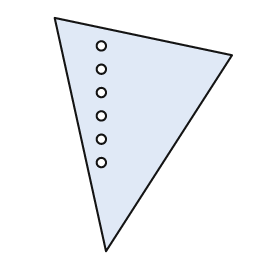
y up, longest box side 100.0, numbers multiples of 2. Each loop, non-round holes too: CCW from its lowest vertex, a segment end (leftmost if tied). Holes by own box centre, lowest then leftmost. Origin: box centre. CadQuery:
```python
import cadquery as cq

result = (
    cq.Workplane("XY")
    .moveTo(-16.0, -50.0)
    .lineTo(38.0, 34.0)
    .lineTo(-38.0, 50.0)
    .close()
    .moveTo(-18.0, -12.0)
    .circle(2.0)
    .moveTo(-18.0, -2.0)
    .circle(2.0)
    .moveTo(-18.0, 8.0)
    .circle(2.0)
    .moveTo(-18.0, 18.0)
    .circle(2.0)
    .moveTo(-18.0, 28.0)
    .circle(2.0)
    .moveTo(-18.0, 38.0)
    .circle(2.0)
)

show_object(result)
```